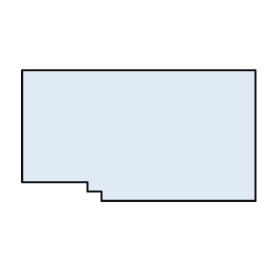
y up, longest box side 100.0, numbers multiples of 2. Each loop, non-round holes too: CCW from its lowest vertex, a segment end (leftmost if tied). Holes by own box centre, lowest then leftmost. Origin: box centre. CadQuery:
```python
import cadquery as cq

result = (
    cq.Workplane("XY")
    .moveTo(-16.0, -28.0)
    .lineTo(50.0, -28.0)
    .lineTo(50.0, 28.0)
    .lineTo(-50.0, 28.0)
    .lineTo(-50.0, -20.0)
    .lineTo(-22.0, -20.0)
    .lineTo(-22.0, -24.0)
    .lineTo(-16.0, -24.0)
    .close()
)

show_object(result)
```